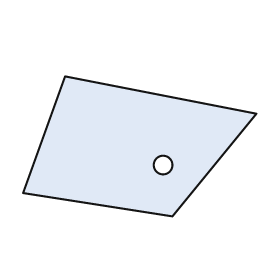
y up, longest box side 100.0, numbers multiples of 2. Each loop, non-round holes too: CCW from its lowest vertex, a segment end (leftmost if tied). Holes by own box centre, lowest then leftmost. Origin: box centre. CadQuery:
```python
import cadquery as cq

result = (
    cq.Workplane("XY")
    .moveTo(14.0, -30.0)
    .lineTo(50.0, 14.0)
    .lineTo(-32.0, 30.0)
    .lineTo(-50.0, -20.0)
    .close()
    .moveTo(10.0, -8.0)
    .circle(4.0)
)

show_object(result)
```